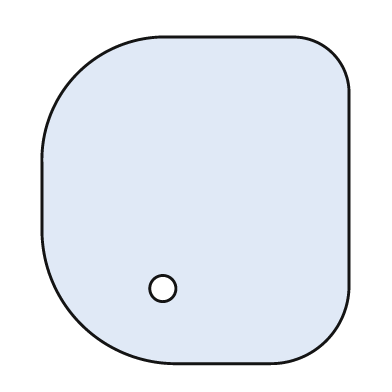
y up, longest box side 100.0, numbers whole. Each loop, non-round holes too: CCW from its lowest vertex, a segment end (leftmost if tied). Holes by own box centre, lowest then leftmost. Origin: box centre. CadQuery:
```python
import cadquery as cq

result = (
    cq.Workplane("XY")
    .moveTo(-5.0, -50.0)
    .lineTo(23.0, -50.0)
    .threePointArc((40.0, -43.0), (47.0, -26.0))
    .lineTo(47.0, 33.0)
    .threePointArc((42.0, 45.0), (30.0, 50.0))
    .lineTo(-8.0, 50.0)
    .threePointArc((-36.0, 39.0), (-47.0, 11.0))
    .lineTo(-47.0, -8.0)
    .threePointArc((-35.0, -38.0), (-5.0, -50.0))
    .close()
    .moveTo(-10.0, -27.0)
    .circle(4.0)
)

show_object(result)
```